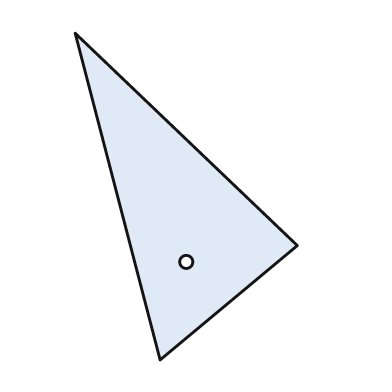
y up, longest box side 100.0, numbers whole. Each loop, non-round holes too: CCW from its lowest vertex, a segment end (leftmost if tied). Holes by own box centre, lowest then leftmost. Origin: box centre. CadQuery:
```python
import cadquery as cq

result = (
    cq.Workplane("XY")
    .moveTo(-8.0, -50.0)
    .lineTo(34.0, -15.0)
    .lineTo(-34.0, 50.0)
    .close()
    .moveTo(0.0, -20.0)
    .circle(2.0)
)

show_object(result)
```